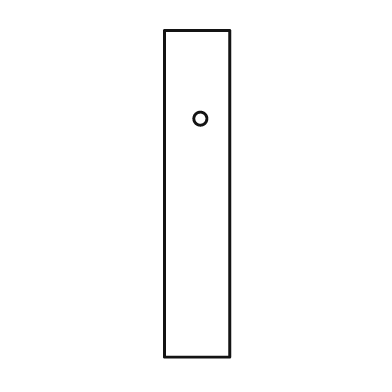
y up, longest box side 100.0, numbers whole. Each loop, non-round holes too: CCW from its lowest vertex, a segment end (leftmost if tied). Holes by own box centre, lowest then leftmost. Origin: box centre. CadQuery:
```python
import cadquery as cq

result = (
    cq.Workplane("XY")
    .moveTo(-10.0, -50.0)
    .lineTo(10.0, -50.0)
    .lineTo(10.0, 50.0)
    .lineTo(-10.0, 50.0)
    .close()
    .moveTo(1.0, 23.0)
    .circle(2.0)
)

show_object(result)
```